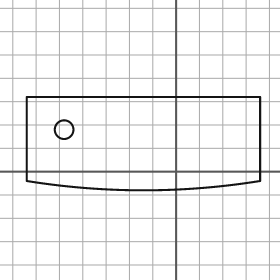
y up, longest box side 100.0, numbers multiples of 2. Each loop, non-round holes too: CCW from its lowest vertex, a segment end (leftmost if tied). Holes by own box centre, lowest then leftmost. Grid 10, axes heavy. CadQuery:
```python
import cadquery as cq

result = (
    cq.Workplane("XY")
    .moveTo(-64.0, -4.0)
    .threePointArc((-14.0, -8.0), (36.0, -4.0))
    .lineTo(36.0, 32.0)
    .lineTo(-64.0, 32.0)
    .close()
    .moveTo(-48.0, 18.0)
    .circle(4.0)
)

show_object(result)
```